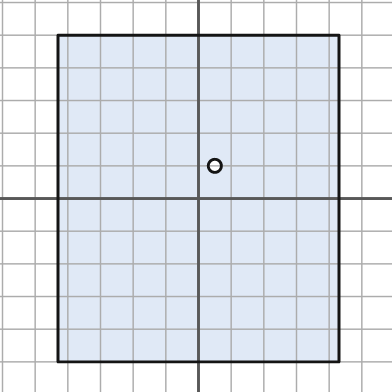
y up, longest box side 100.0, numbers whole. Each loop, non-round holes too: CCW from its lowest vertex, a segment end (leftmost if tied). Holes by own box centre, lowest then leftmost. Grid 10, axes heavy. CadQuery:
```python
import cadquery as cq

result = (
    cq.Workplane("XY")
    .moveTo(-43.0, -50.0)
    .lineTo(43.0, -50.0)
    .lineTo(43.0, 50.0)
    .lineTo(-43.0, 50.0)
    .close()
    .moveTo(5.0, 10.0)
    .circle(2.0)
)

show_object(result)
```